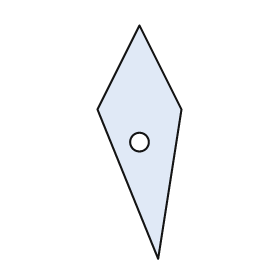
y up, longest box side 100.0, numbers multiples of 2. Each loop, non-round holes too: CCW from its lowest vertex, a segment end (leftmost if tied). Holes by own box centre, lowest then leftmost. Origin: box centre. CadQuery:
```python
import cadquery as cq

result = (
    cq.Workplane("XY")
    .moveTo(8.0, -50.0)
    .lineTo(18.0, 14.0)
    .lineTo(0.0, 50.0)
    .lineTo(-18.0, 14.0)
    .close()
    .moveTo(0.0, 0.0)
    .circle(4.0)
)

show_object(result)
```